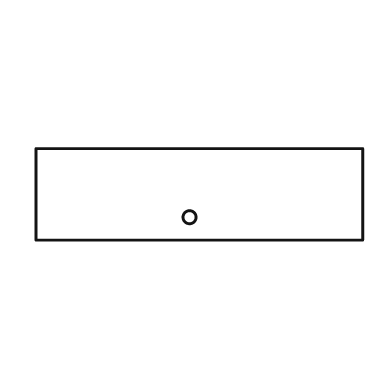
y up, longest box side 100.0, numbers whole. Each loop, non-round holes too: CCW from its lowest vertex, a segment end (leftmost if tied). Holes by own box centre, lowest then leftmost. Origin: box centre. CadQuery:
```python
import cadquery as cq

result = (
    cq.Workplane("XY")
    .moveTo(-50.0, -14.0)
    .lineTo(50.0, -14.0)
    .lineTo(50.0, 14.0)
    .lineTo(-50.0, 14.0)
    .close()
    .moveTo(-3.0, -7.0)
    .circle(2.0)
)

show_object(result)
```